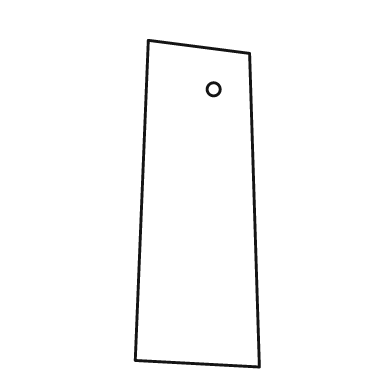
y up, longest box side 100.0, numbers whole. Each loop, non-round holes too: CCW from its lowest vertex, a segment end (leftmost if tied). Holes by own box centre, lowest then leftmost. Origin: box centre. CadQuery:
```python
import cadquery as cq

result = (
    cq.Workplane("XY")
    .moveTo(19.0, -50.0)
    .lineTo(16.0, 46.0)
    .lineTo(-15.0, 50.0)
    .lineTo(-19.0, -48.0)
    .close()
    .moveTo(5.0, 35.0)
    .circle(2.0)
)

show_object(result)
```